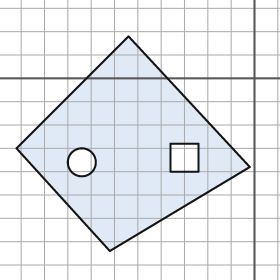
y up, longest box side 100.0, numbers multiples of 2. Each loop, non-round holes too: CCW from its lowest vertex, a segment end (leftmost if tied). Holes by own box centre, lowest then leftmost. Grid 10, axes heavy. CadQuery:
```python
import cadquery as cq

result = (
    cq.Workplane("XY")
    .moveTo(-62.0, -74.0)
    .lineTo(-2.0, -38.0)
    .lineTo(-54.0, 18.0)
    .lineTo(-102.0, -30.0)
    .close()
    .moveTo(-74.0, -36.0)
    .circle(6.0)
    .moveTo(-36.0, -40.0)
    .lineTo(-24.0, -40.0)
    .lineTo(-24.0, -28.0)
    .lineTo(-36.0, -28.0)
    .close()
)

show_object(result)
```